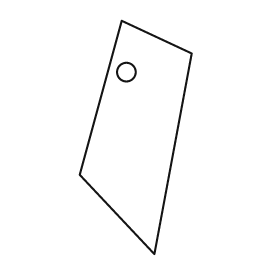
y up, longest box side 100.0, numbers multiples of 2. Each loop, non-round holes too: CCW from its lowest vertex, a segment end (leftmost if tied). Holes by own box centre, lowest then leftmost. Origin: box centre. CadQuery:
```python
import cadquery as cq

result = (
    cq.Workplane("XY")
    .moveTo(8.0, -50.0)
    .lineTo(24.0, 36.0)
    .lineTo(-6.0, 50.0)
    .lineTo(-24.0, -16.0)
    .close()
    .moveTo(-4.0, 28.0)
    .circle(4.0)
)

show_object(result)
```